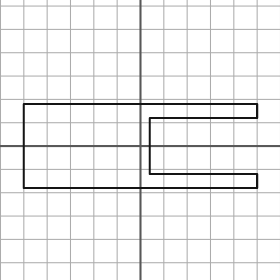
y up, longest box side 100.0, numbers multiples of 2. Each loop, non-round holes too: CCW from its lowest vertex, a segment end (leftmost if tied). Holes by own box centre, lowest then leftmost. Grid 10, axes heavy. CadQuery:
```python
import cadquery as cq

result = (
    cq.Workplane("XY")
    .moveTo(-50.0, -18.0)
    .lineTo(50.0, -18.0)
    .lineTo(50.0, -12.0)
    .lineTo(4.0, -12.0)
    .lineTo(4.0, 12.0)
    .lineTo(50.0, 12.0)
    .lineTo(50.0, 18.0)
    .lineTo(-50.0, 18.0)
    .close()
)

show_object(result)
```